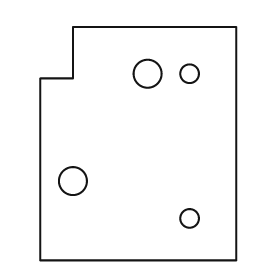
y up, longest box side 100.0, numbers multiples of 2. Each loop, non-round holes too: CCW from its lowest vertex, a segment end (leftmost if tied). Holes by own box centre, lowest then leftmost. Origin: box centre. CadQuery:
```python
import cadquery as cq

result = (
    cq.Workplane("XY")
    .moveTo(-42.0, -50.0)
    .lineTo(42.0, -50.0)
    .lineTo(42.0, 50.0)
    .lineTo(-28.0, 50.0)
    .lineTo(-28.0, 28.0)
    .lineTo(-42.0, 28.0)
    .close()
    .moveTo(22.0, -32.0)
    .circle(4.0)
    .moveTo(-28.0, -16.0)
    .circle(6.0)
    .moveTo(4.0, 30.0)
    .circle(6.0)
    .moveTo(22.0, 30.0)
    .circle(4.0)
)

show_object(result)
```